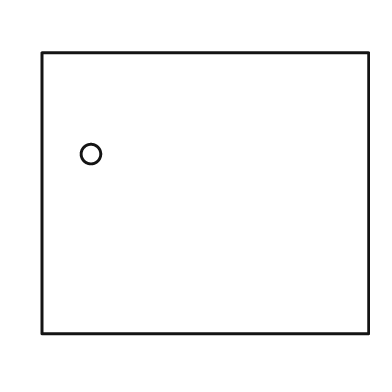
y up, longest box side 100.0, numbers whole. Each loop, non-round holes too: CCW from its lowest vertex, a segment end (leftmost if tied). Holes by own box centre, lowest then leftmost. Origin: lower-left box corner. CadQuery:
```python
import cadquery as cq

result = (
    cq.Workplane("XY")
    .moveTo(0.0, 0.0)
    .lineTo(100.0, 0.0)
    .lineTo(100.0, 86.0)
    .lineTo(0.0, 86.0)
    .close()
    .moveTo(15.0, 55.0)
    .circle(3.0)
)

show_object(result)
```